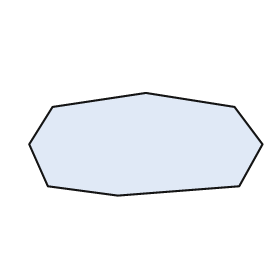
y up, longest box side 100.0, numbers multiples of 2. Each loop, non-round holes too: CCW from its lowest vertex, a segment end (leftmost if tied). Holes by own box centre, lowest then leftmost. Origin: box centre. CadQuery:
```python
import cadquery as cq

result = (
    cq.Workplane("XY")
    .moveTo(-12.0, -22.0)
    .lineTo(40.0, -18.0)
    .lineTo(50.0, 0.0)
    .lineTo(38.0, 16.0)
    .lineTo(0.0, 22.0)
    .lineTo(-40.0, 16.0)
    .lineTo(-50.0, 0.0)
    .lineTo(-42.0, -18.0)
    .close()
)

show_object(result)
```